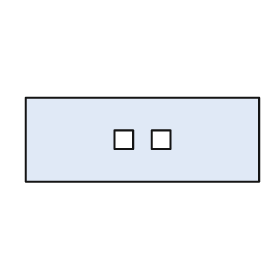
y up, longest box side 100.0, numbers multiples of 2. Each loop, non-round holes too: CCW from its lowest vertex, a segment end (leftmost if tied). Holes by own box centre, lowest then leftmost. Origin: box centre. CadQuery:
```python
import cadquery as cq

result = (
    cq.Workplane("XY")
    .moveTo(-50.0, -18.0)
    .lineTo(50.0, -18.0)
    .lineTo(50.0, 18.0)
    .lineTo(-50.0, 18.0)
    .close()
    .moveTo(-12.0, -4.0)
    .lineTo(-4.0, -4.0)
    .lineTo(-4.0, 4.0)
    .lineTo(-12.0, 4.0)
    .close()
    .moveTo(4.0, -4.0)
    .lineTo(12.0, -4.0)
    .lineTo(12.0, 4.0)
    .lineTo(4.0, 4.0)
    .close()
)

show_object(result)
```